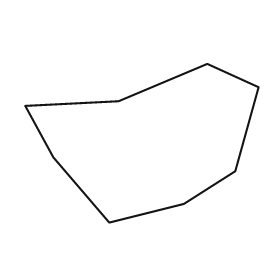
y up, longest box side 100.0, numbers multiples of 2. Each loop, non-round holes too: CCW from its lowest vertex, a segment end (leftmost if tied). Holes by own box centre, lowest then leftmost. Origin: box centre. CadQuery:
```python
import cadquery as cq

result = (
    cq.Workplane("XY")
    .moveTo(-14.0, -34.0)
    .lineTo(18.0, -26.0)
    .lineTo(40.0, -12.0)
    .lineTo(50.0, 24.0)
    .lineTo(28.0, 34.0)
    .lineTo(-10.0, 18.0)
    .lineTo(-50.0, 16.0)
    .lineTo(-38.0, -6.0)
    .close()
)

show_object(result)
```